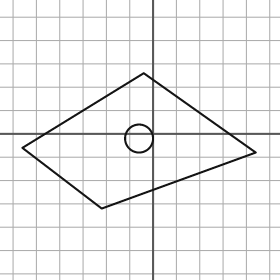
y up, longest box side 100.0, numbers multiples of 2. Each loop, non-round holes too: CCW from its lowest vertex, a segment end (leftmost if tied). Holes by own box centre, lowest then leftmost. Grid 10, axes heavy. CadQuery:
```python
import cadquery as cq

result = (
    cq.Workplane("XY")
    .moveTo(-22.0, -32.0)
    .lineTo(44.0, -8.0)
    .lineTo(-4.0, 26.0)
    .lineTo(-56.0, -6.0)
    .close()
    .moveTo(-6.0, -2.0)
    .circle(6.0)
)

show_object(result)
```